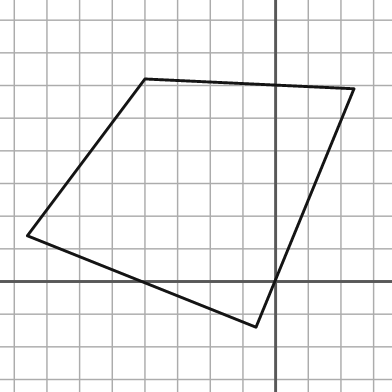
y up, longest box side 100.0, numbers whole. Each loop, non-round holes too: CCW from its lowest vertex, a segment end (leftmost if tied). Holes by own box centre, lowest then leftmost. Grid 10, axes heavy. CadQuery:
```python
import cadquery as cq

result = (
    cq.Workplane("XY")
    .moveTo(-6.0, -14.0)
    .lineTo(24.0, 59.0)
    .lineTo(-40.0, 62.0)
    .lineTo(-76.0, 14.0)
    .close()
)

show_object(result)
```